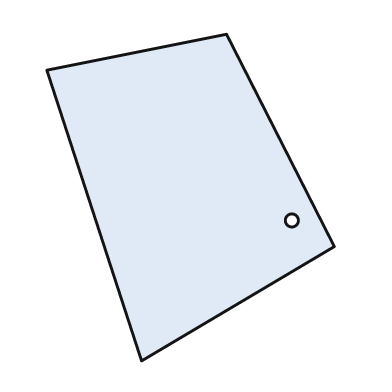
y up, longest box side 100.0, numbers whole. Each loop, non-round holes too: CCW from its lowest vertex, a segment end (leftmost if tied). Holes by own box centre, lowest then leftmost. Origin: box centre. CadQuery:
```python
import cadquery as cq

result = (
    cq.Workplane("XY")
    .moveTo(-15.0, -50.0)
    .lineTo(44.0, -15.0)
    .lineTo(11.0, 50.0)
    .lineTo(-44.0, 39.0)
    .close()
    .moveTo(31.0, -7.0)
    .circle(2.0)
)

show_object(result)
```